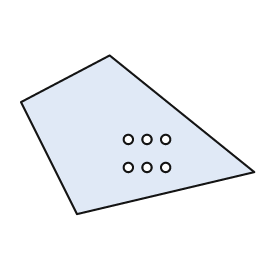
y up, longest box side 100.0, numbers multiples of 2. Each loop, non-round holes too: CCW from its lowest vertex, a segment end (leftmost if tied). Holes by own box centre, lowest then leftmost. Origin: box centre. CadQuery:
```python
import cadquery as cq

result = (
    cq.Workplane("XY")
    .moveTo(-26.0, -34.0)
    .lineTo(50.0, -16.0)
    .lineTo(-12.0, 34.0)
    .lineTo(-50.0, 14.0)
    .close()
    .moveTo(-4.0, -14.0)
    .circle(2.0)
    .moveTo(4.0, -14.0)
    .circle(2.0)
    .moveTo(12.0, -14.0)
    .circle(2.0)
    .moveTo(-4.0, -2.0)
    .circle(2.0)
    .moveTo(4.0, -2.0)
    .circle(2.0)
    .moveTo(12.0, -2.0)
    .circle(2.0)
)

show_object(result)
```